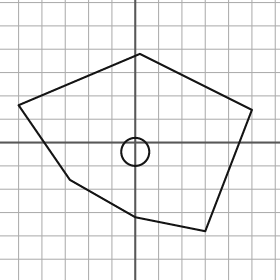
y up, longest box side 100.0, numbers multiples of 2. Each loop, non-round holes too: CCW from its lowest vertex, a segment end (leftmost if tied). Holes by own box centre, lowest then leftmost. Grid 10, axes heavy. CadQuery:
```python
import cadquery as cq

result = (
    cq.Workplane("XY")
    .moveTo(30.0, -38.0)
    .lineTo(50.0, 14.0)
    .lineTo(2.0, 38.0)
    .lineTo(-50.0, 16.0)
    .lineTo(-28.0, -16.0)
    .lineTo(0.0, -32.0)
    .close()
    .moveTo(0.0, -4.0)
    .circle(6.0)
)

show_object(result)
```